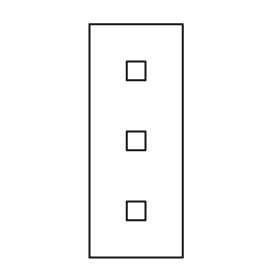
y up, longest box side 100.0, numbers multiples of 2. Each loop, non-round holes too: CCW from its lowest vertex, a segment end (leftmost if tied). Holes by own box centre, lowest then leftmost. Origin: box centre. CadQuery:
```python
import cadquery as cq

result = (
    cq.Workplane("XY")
    .moveTo(-20.0, -50.0)
    .lineTo(20.0, -50.0)
    .lineTo(20.0, 50.0)
    .lineTo(-20.0, 50.0)
    .close()
    .moveTo(-4.0, -34.0)
    .lineTo(4.0, -34.0)
    .lineTo(4.0, -26.0)
    .lineTo(-4.0, -26.0)
    .close()
    .moveTo(-4.0, -4.0)
    .lineTo(4.0, -4.0)
    .lineTo(4.0, 4.0)
    .lineTo(-4.0, 4.0)
    .close()
    .moveTo(-4.0, 26.0)
    .lineTo(4.0, 26.0)
    .lineTo(4.0, 34.0)
    .lineTo(-4.0, 34.0)
    .close()
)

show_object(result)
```